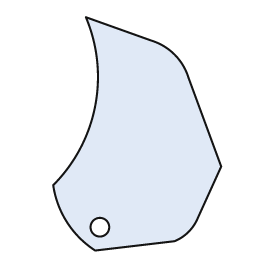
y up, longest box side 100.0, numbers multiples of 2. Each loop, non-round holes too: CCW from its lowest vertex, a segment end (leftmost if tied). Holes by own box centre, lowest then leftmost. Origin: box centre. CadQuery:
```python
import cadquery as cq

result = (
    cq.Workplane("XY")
    .moveTo(-18.0, -50.0)
    .lineTo(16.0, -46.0)
    .threePointArc((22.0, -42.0), (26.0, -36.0))
    .lineTo(36.0, -14.0)
    .lineTo(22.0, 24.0)
    .threePointArc((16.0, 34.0), (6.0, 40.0))
    .lineTo(-22.0, 50.0)
    .threePointArc((-18.0, 12.0), (-36.0, -22.0))
    .threePointArc((-30.0, -38.0), (-18.0, -50.0))
    .close()
    .moveTo(-16.0, -40.0)
    .circle(4.0)
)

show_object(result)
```